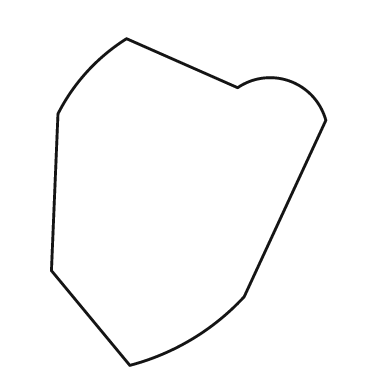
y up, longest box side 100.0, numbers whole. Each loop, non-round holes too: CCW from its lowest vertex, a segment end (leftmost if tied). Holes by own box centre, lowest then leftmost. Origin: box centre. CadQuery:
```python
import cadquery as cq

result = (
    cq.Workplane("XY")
    .moveTo(-18.0, -50.0)
    .threePointArc((1.0, -42.0), (17.0, -29.0))
    .lineTo(42.0, 25.0)
    .threePointArc((31.0, 37.0), (15.0, 35.0))
    .lineTo(-19.0, 50.0)
    .threePointArc((-31.0, 40.0), (-40.0, 27.0))
    .lineTo(-42.0, -21.0)
    .close()
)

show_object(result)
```